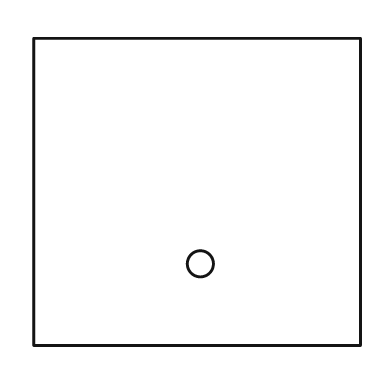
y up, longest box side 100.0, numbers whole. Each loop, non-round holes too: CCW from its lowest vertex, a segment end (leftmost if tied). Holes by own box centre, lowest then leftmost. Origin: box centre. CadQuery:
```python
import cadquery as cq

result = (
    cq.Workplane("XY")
    .moveTo(-50.0, -47.0)
    .lineTo(50.0, -47.0)
    .lineTo(50.0, 47.0)
    .lineTo(-50.0, 47.0)
    .close()
    .moveTo(1.0, -22.0)
    .circle(4.0)
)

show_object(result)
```